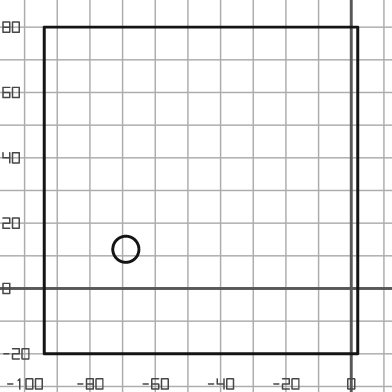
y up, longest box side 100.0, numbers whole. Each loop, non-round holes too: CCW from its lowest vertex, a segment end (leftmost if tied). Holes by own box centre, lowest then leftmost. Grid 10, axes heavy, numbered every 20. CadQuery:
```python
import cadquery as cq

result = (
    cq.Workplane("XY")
    .moveTo(-94.0, -20.0)
    .lineTo(2.0, -20.0)
    .lineTo(2.0, 80.0)
    .lineTo(-94.0, 80.0)
    .close()
    .moveTo(-69.0, 12.0)
    .circle(4.0)
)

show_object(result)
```